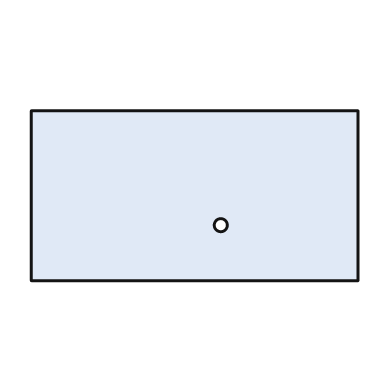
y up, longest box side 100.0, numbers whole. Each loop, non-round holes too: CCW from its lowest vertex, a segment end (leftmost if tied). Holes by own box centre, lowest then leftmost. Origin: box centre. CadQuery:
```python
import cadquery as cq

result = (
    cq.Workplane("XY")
    .moveTo(-50.0, -26.0)
    .lineTo(50.0, -26.0)
    .lineTo(50.0, 26.0)
    .lineTo(-50.0, 26.0)
    .close()
    .moveTo(8.0, -9.0)
    .circle(2.0)
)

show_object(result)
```